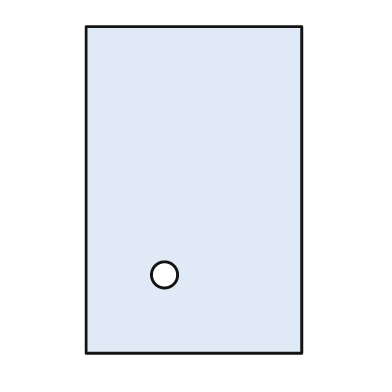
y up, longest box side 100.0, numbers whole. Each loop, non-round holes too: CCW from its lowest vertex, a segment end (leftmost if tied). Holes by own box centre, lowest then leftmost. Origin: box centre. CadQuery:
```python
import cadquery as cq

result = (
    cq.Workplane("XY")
    .moveTo(-33.0, -50.0)
    .lineTo(33.0, -50.0)
    .lineTo(33.0, 50.0)
    .lineTo(-33.0, 50.0)
    .close()
    .moveTo(-9.0, -26.0)
    .circle(4.0)
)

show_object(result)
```